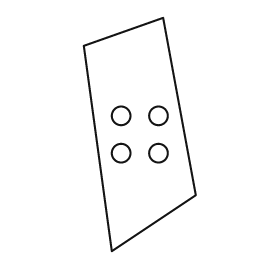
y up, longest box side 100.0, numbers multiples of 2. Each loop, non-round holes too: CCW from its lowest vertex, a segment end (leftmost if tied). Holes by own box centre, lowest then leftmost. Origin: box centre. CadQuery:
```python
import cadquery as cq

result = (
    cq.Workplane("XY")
    .moveTo(-12.0, -50.0)
    .lineTo(24.0, -26.0)
    .lineTo(10.0, 50.0)
    .lineTo(-24.0, 38.0)
    .close()
    .moveTo(-8.0, -8.0)
    .circle(4.0)
    .moveTo(8.0, -8.0)
    .circle(4.0)
    .moveTo(-8.0, 8.0)
    .circle(4.0)
    .moveTo(8.0, 8.0)
    .circle(4.0)
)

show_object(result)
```